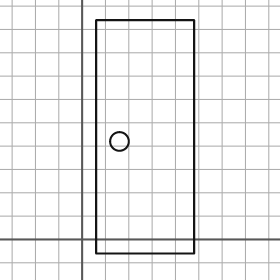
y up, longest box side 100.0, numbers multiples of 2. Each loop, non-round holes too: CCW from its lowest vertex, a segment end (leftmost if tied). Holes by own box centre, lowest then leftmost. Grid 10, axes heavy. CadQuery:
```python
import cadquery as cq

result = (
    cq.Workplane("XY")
    .moveTo(6.0, -6.0)
    .lineTo(48.0, -6.0)
    .lineTo(48.0, 94.0)
    .lineTo(6.0, 94.0)
    .close()
    .moveTo(16.0, 42.0)
    .circle(4.0)
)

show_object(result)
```